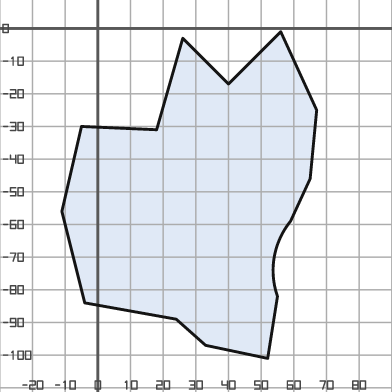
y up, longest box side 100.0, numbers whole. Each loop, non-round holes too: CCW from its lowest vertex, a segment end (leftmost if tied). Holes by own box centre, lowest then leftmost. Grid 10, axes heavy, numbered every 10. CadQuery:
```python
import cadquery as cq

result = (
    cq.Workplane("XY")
    .moveTo(52.0, -101.0)
    .lineTo(55.0, -82.0)
    .threePointArc((54.0, -70.0), (59.0, -59.0))
    .lineTo(65.0, -46.0)
    .lineTo(67.0, -25.0)
    .lineTo(56.0, -1.0)
    .lineTo(40.0, -17.0)
    .lineTo(26.0, -3.0)
    .lineTo(18.0, -31.0)
    .lineTo(-5.0, -30.0)
    .lineTo(-11.0, -56.0)
    .lineTo(-4.0, -84.0)
    .lineTo(24.0, -89.0)
    .lineTo(33.0, -97.0)
    .close()
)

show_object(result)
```